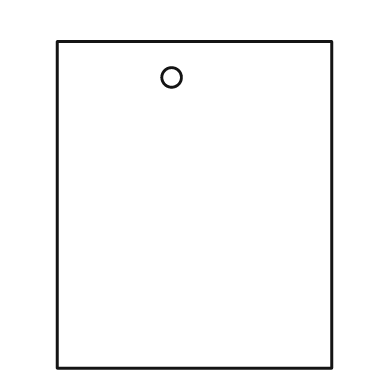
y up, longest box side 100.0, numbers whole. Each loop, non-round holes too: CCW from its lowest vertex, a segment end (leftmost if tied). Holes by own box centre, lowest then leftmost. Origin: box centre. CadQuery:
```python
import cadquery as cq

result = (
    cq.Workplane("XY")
    .moveTo(-42.0, -50.0)
    .lineTo(42.0, -50.0)
    .lineTo(42.0, 50.0)
    .lineTo(-42.0, 50.0)
    .close()
    .moveTo(-7.0, 39.0)
    .circle(3.0)
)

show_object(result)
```